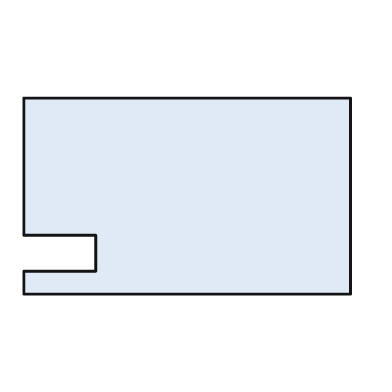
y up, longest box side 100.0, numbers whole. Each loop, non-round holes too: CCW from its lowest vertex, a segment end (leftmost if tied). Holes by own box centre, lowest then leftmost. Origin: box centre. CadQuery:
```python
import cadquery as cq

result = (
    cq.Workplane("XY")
    .moveTo(-50.0, -30.0)
    .lineTo(50.0, -30.0)
    .lineTo(50.0, 30.0)
    .lineTo(-50.0, 30.0)
    .lineTo(-50.0, -12.0)
    .lineTo(-28.0, -12.0)
    .lineTo(-28.0, -23.0)
    .lineTo(-50.0, -23.0)
    .close()
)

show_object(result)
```